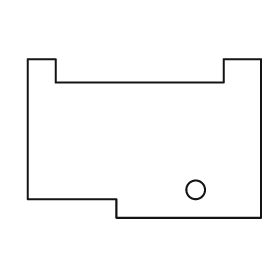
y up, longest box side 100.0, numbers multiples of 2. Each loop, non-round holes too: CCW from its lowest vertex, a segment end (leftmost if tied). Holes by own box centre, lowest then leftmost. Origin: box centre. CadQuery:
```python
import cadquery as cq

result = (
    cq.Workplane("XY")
    .moveTo(-12.0, -34.0)
    .lineTo(50.0, -34.0)
    .lineTo(50.0, 34.0)
    .lineTo(34.0, 34.0)
    .lineTo(34.0, 24.0)
    .lineTo(-38.0, 24.0)
    .lineTo(-38.0, 34.0)
    .lineTo(-50.0, 34.0)
    .lineTo(-50.0, -26.0)
    .lineTo(-12.0, -26.0)
    .close()
    .moveTo(22.0, -22.0)
    .circle(4.0)
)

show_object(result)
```